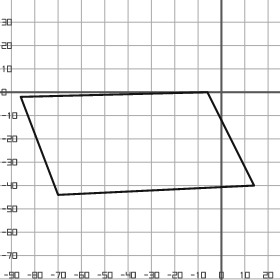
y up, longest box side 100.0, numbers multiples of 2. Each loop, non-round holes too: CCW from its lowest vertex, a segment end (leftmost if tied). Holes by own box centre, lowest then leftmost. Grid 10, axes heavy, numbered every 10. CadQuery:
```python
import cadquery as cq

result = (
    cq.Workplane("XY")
    .moveTo(-70.0, -44.0)
    .lineTo(14.0, -40.0)
    .lineTo(-6.0, 0.0)
    .lineTo(-86.0, -2.0)
    .close()
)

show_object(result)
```